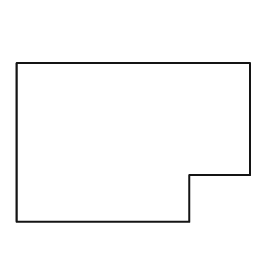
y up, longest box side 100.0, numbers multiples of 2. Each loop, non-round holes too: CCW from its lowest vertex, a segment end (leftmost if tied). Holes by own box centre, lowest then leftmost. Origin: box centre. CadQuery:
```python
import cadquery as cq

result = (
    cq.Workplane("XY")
    .moveTo(-50.0, -34.0)
    .lineTo(24.0, -34.0)
    .lineTo(24.0, -14.0)
    .lineTo(50.0, -14.0)
    .lineTo(50.0, 34.0)
    .lineTo(-50.0, 34.0)
    .close()
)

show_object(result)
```